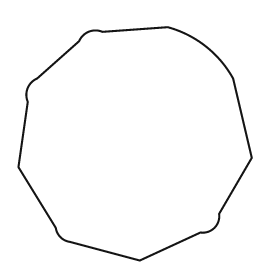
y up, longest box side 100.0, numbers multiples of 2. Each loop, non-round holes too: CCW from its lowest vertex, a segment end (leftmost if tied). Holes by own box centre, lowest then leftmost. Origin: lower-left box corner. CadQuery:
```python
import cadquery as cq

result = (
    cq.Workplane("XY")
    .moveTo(52.0, 0.0)
    .lineTo(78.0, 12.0)
    .threePointArc((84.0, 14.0), (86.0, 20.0))
    .lineTo(100.0, 44.0)
    .lineTo(92.0, 78.0)
    .threePointArc((80.0, 92.0), (64.0, 100.0))
    .lineTo(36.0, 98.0)
    .threePointArc((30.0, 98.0), (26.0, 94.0))
    .lineTo(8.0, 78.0)
    .threePointArc((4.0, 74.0), (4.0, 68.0))
    .lineTo(0.0, 40.0)
    .lineTo(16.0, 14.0)
    .threePointArc((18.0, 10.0), (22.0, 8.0))
    .close()
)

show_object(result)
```